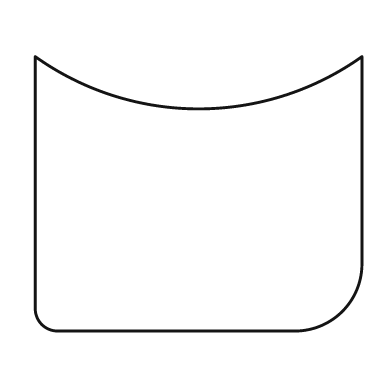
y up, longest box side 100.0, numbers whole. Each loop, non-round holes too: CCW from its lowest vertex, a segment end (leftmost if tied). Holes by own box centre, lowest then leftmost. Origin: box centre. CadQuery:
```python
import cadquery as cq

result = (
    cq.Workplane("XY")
    .moveTo(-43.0, -42.0)
    .lineTo(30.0, -42.0)
    .threePointArc((44.0, -36.0), (50.0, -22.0))
    .lineTo(50.0, 42.0)
    .threePointArc((0.0, 26.0), (-50.0, 42.0))
    .lineTo(-50.0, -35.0)
    .threePointArc((-48.0, -40.0), (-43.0, -42.0))
    .close()
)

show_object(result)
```